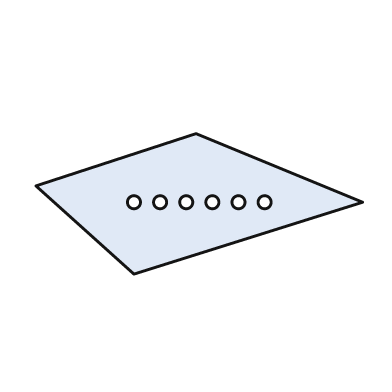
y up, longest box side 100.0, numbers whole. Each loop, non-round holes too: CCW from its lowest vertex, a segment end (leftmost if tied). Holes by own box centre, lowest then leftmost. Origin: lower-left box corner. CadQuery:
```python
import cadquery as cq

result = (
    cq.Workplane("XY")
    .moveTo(30.0, 0.0)
    .lineTo(100.0, 22.0)
    .lineTo(49.0, 43.0)
    .lineTo(0.0, 27.0)
    .close()
    .moveTo(30.0, 22.0)
    .circle(2.0)
    .moveTo(38.0, 22.0)
    .circle(2.0)
    .moveTo(46.0, 22.0)
    .circle(2.0)
    .moveTo(54.0, 22.0)
    .circle(2.0)
    .moveTo(62.0, 22.0)
    .circle(2.0)
    .moveTo(70.0, 22.0)
    .circle(2.0)
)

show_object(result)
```